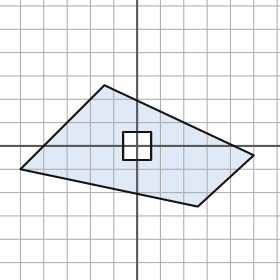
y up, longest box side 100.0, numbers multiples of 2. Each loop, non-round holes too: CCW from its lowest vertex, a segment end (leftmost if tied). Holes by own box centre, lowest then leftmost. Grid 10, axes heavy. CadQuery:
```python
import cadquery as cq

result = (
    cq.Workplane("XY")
    .moveTo(26.0, -26.0)
    .lineTo(50.0, -4.0)
    .lineTo(-14.0, 26.0)
    .lineTo(-50.0, -10.0)
    .close()
    .moveTo(-6.0, -6.0)
    .lineTo(6.0, -6.0)
    .lineTo(6.0, 6.0)
    .lineTo(-6.0, 6.0)
    .close()
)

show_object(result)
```